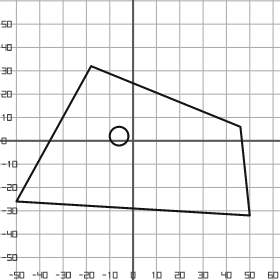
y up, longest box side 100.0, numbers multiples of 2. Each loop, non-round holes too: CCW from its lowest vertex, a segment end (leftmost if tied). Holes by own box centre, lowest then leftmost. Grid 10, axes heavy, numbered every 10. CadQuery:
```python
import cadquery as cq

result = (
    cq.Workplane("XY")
    .moveTo(50.0, -32.0)
    .lineTo(46.0, 6.0)
    .lineTo(-18.0, 32.0)
    .lineTo(-50.0, -26.0)
    .close()
    .moveTo(-6.0, 2.0)
    .circle(4.0)
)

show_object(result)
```